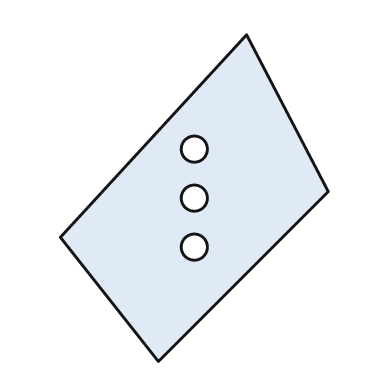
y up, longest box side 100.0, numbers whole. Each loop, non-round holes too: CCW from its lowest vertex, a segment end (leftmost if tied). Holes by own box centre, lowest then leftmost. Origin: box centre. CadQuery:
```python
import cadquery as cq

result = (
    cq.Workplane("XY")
    .moveTo(-11.0, -50.0)
    .lineTo(41.0, 2.0)
    .lineTo(16.0, 50.0)
    .lineTo(-41.0, -12.0)
    .close()
    .moveTo(0.0, -15.0)
    .circle(4.0)
    .moveTo(0.0, 0.0)
    .circle(4.0)
    .moveTo(0.0, 15.0)
    .circle(4.0)
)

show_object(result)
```